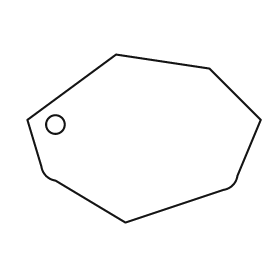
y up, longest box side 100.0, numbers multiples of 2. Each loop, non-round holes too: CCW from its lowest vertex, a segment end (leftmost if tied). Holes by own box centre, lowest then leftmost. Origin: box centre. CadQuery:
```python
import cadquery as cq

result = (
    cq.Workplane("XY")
    .moveTo(-8.0, -36.0)
    .lineTo(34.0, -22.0)
    .threePointArc((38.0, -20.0), (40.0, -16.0))
    .lineTo(50.0, 8.0)
    .lineTo(28.0, 30.0)
    .lineTo(-12.0, 36.0)
    .lineTo(-50.0, 8.0)
    .lineTo(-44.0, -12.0)
    .threePointArc((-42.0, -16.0), (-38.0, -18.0))
    .close()
    .moveTo(-38.0, 6.0)
    .circle(4.0)
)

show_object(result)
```